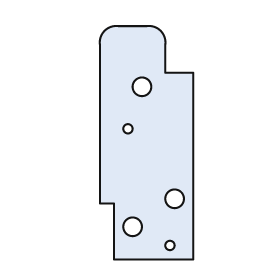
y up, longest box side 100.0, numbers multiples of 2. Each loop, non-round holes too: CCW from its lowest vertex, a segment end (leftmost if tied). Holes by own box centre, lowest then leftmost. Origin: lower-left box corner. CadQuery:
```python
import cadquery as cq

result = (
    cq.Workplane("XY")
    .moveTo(6.0, 0.0)
    .lineTo(40.0, 0.0)
    .lineTo(40.0, 80.0)
    .lineTo(28.0, 80.0)
    .lineTo(28.0, 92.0)
    .threePointArc((26.0, 98.0), (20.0, 100.0))
    .lineTo(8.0, 100.0)
    .threePointArc((2.0, 98.0), (0.0, 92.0))
    .lineTo(0.0, 24.0)
    .lineTo(6.0, 24.0)
    .close()
    .moveTo(30.0, 6.0)
    .circle(2.0)
    .moveTo(14.0, 14.0)
    .circle(4.0)
    .moveTo(32.0, 26.0)
    .circle(4.0)
    .moveTo(12.0, 56.0)
    .circle(2.0)
    .moveTo(18.0, 74.0)
    .circle(4.0)
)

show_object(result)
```